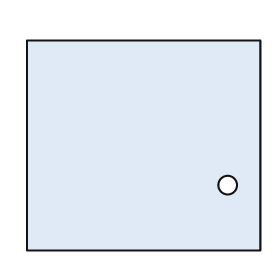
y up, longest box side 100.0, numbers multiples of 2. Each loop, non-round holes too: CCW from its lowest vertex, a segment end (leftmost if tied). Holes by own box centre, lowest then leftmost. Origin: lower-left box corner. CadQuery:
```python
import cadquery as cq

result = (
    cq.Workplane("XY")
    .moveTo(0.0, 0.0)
    .lineTo(100.0, 0.0)
    .lineTo(100.0, 90.0)
    .lineTo(0.0, 90.0)
    .close()
    .moveTo(86.0, 28.0)
    .circle(4.0)
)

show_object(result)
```